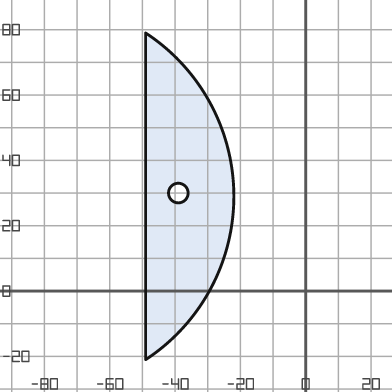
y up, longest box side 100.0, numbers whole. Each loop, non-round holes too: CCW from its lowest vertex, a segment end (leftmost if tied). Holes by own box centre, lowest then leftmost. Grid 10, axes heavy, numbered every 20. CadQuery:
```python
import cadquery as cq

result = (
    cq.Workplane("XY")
    .moveTo(-49.0, -21.0)
    .threePointArc((-22.0, 29.0), (-49.0, 79.0))
    .close()
    .moveTo(-39.0, 30.0)
    .circle(3.0)
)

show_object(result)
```